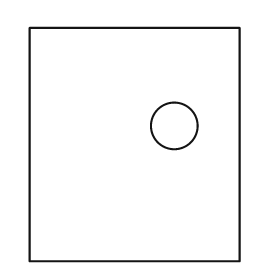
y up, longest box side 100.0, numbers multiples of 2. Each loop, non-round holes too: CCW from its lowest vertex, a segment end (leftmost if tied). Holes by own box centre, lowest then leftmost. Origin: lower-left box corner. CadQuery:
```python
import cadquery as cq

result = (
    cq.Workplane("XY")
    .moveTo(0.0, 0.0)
    .lineTo(90.0, 0.0)
    .lineTo(90.0, 100.0)
    .lineTo(0.0, 100.0)
    .close()
    .moveTo(62.0, 58.0)
    .circle(10.0)
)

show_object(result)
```